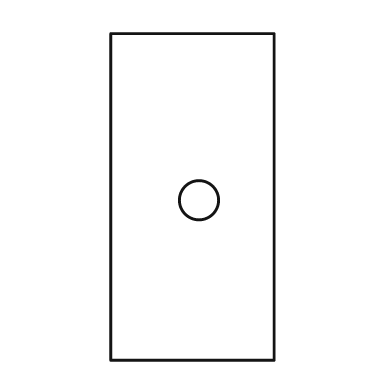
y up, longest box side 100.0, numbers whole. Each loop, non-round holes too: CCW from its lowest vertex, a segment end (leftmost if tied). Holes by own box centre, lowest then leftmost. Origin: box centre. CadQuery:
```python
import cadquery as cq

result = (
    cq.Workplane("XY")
    .moveTo(-25.0, -50.0)
    .lineTo(25.0, -50.0)
    .lineTo(25.0, 50.0)
    .lineTo(-25.0, 50.0)
    .close()
    .moveTo(2.0, -1.0)
    .circle(6.0)
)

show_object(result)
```